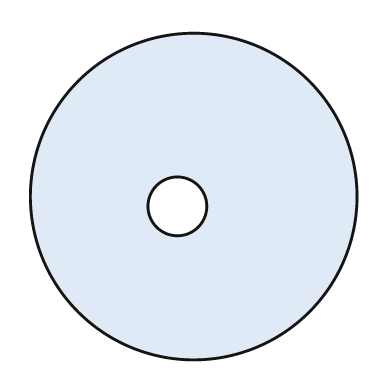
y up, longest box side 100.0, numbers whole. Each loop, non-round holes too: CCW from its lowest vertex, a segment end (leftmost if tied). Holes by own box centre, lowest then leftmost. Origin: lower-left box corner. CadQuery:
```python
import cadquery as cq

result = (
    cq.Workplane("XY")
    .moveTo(50.0, 50.0)
    .circle(50.0)
    .moveTo(45.0, 47.0)
    .circle(9.0)
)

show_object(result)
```